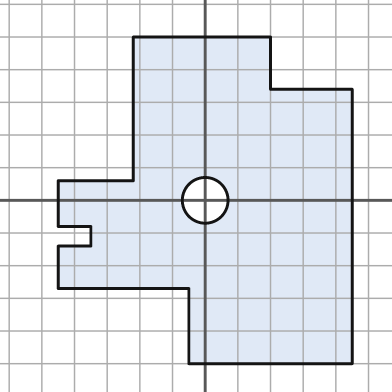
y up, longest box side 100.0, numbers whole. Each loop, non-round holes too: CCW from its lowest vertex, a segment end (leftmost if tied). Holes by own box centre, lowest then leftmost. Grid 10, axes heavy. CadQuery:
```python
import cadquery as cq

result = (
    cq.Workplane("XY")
    .moveTo(-5.0, -50.0)
    .lineTo(45.0, -50.0)
    .lineTo(45.0, 34.0)
    .lineTo(20.0, 34.0)
    .lineTo(20.0, 50.0)
    .lineTo(-22.0, 50.0)
    .lineTo(-22.0, 6.0)
    .lineTo(-45.0, 6.0)
    .lineTo(-45.0, -8.0)
    .lineTo(-35.0, -8.0)
    .lineTo(-35.0, -14.0)
    .lineTo(-45.0, -14.0)
    .lineTo(-45.0, -27.0)
    .lineTo(-5.0, -27.0)
    .close()
    .moveTo(0.0, 0.0)
    .circle(7.0)
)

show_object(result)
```